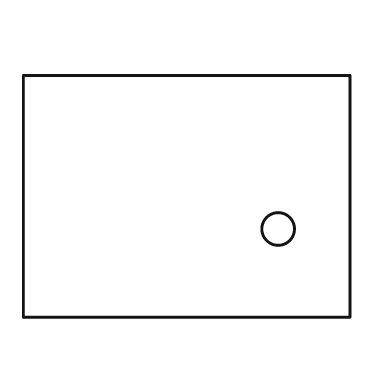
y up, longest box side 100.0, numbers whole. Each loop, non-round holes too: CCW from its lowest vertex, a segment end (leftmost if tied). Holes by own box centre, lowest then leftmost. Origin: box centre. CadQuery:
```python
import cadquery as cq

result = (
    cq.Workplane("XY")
    .moveTo(-50.0, -37.0)
    .lineTo(50.0, -37.0)
    .lineTo(50.0, 37.0)
    .lineTo(-50.0, 37.0)
    .close()
    .moveTo(28.0, -10.0)
    .circle(5.0)
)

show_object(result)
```